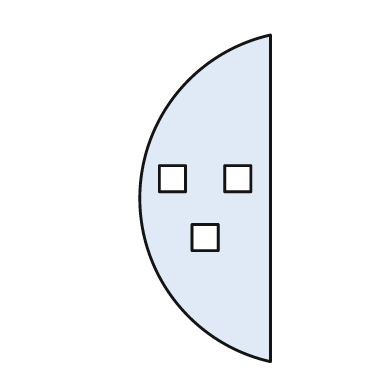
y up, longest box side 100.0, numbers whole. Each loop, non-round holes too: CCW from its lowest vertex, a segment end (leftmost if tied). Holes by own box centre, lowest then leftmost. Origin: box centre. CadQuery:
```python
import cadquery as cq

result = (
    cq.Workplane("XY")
    .moveTo(20.0, -50.0)
    .lineTo(20.0, 50.0)
    .threePointArc((-20.0, 0.0), (20.0, -50.0))
    .close()
    .moveTo(-4.0, -16.0)
    .lineTo(4.0, -16.0)
    .lineTo(4.0, -8.0)
    .lineTo(-4.0, -8.0)
    .close()
    .moveTo(-14.0, 2.0)
    .lineTo(-6.0, 2.0)
    .lineTo(-6.0, 10.0)
    .lineTo(-14.0, 10.0)
    .close()
    .moveTo(6.0, 2.0)
    .lineTo(14.0, 2.0)
    .lineTo(14.0, 10.0)
    .lineTo(6.0, 10.0)
    .close()
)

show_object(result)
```